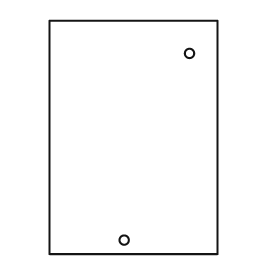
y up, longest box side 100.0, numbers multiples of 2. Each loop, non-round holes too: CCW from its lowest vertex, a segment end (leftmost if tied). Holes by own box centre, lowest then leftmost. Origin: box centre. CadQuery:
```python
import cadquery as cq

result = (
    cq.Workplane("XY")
    .moveTo(-36.0, -50.0)
    .lineTo(36.0, -50.0)
    .lineTo(36.0, 50.0)
    .lineTo(-36.0, 50.0)
    .close()
    .moveTo(-4.0, -44.0)
    .circle(2.0)
    .moveTo(24.0, 36.0)
    .circle(2.0)
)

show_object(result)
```